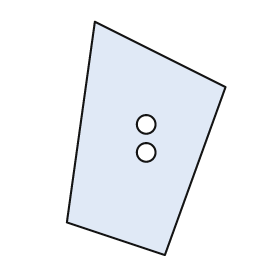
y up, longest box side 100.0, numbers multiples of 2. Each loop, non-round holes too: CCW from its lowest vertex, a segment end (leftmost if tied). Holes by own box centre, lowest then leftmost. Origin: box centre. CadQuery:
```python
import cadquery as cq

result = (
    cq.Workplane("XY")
    .moveTo(8.0, -50.0)
    .lineTo(34.0, 22.0)
    .lineTo(-22.0, 50.0)
    .lineTo(-34.0, -36.0)
    .close()
    .moveTo(0.0, -6.0)
    .circle(4.0)
    .moveTo(0.0, 6.0)
    .circle(4.0)
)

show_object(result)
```